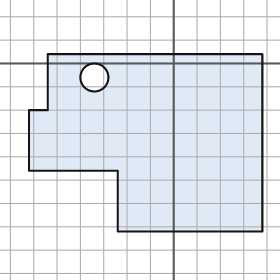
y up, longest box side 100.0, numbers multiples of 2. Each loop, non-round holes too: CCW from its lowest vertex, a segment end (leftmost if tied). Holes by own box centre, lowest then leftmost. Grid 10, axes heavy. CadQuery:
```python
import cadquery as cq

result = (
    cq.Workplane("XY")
    .moveTo(-24.0, -72.0)
    .lineTo(38.0, -72.0)
    .lineTo(38.0, 4.0)
    .lineTo(-54.0, 4.0)
    .lineTo(-54.0, -20.0)
    .lineTo(-62.0, -20.0)
    .lineTo(-62.0, -46.0)
    .lineTo(-24.0, -46.0)
    .close()
    .moveTo(-34.0, -6.0)
    .circle(6.0)
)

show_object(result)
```